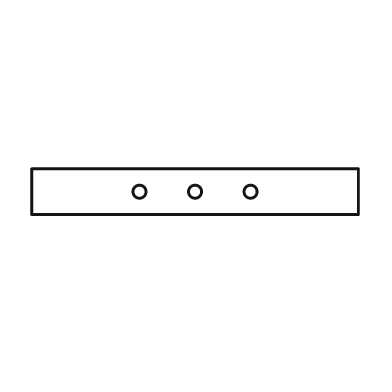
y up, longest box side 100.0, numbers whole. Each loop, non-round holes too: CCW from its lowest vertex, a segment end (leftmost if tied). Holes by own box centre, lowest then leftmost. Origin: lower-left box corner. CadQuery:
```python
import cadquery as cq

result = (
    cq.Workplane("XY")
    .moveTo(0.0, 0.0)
    .lineTo(100.0, 0.0)
    .lineTo(100.0, 14.0)
    .lineTo(0.0, 14.0)
    .close()
    .moveTo(33.0, 7.0)
    .circle(2.0)
    .moveTo(50.0, 7.0)
    .circle(2.0)
    .moveTo(67.0, 7.0)
    .circle(2.0)
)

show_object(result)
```